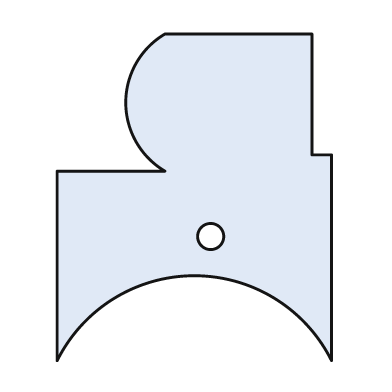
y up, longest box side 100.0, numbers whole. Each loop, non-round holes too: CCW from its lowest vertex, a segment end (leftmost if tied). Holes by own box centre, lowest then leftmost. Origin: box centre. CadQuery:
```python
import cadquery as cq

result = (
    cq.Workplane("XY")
    .moveTo(-42.0, -50.0)
    .threePointArc((0.0, -24.0), (42.0, -50.0))
    .lineTo(42.0, 13.0)
    .lineTo(36.0, 13.0)
    .lineTo(36.0, 50.0)
    .lineTo(-9.0, 50.0)
    .threePointArc((-21.0, 29.0), (-9.0, 8.0))
    .lineTo(-42.0, 8.0)
    .close()
    .moveTo(5.0, -12.0)
    .circle(4.0)
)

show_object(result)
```